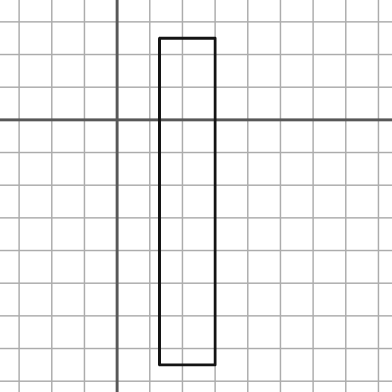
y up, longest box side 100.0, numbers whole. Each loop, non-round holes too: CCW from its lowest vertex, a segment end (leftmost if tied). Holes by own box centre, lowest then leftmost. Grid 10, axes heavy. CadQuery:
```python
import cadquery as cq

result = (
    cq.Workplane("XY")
    .moveTo(13.0, -75.0)
    .lineTo(30.0, -75.0)
    .lineTo(30.0, 25.0)
    .lineTo(13.0, 25.0)
    .close()
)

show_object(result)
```